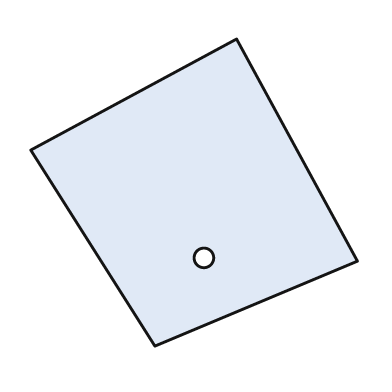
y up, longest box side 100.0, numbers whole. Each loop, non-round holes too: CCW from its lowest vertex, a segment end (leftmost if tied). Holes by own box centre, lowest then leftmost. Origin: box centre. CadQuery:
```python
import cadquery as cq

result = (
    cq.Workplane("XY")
    .moveTo(-12.0, -47.0)
    .lineTo(50.0, -21.0)
    .lineTo(13.0, 47.0)
    .lineTo(-50.0, 13.0)
    .close()
    .moveTo(3.0, -20.0)
    .circle(3.0)
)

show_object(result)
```